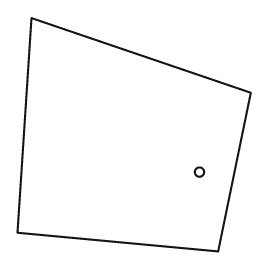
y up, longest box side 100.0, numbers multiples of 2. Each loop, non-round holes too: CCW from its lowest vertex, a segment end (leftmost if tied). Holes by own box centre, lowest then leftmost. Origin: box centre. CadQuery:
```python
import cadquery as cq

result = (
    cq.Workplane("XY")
    .moveTo(36.0, -50.0)
    .lineTo(50.0, 18.0)
    .lineTo(-44.0, 50.0)
    .lineTo(-50.0, -42.0)
    .close()
    .moveTo(28.0, -16.0)
    .circle(2.0)
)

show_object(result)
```